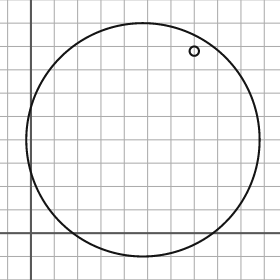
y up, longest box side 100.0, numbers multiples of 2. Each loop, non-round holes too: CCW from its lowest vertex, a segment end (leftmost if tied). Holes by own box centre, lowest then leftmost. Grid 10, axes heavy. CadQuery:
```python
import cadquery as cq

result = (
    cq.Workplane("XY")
    .moveTo(48.0, 40.0)
    .circle(50.0)
    .moveTo(70.0, 78.0)
    .circle(2.0)
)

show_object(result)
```